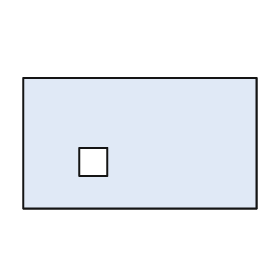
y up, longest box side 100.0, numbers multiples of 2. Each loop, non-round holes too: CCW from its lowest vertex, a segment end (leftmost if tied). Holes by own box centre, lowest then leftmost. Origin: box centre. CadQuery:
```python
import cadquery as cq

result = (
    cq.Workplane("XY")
    .moveTo(-50.0, -28.0)
    .lineTo(50.0, -28.0)
    .lineTo(50.0, 28.0)
    .lineTo(-50.0, 28.0)
    .close()
    .moveTo(-26.0, -14.0)
    .lineTo(-14.0, -14.0)
    .lineTo(-14.0, -2.0)
    .lineTo(-26.0, -2.0)
    .close()
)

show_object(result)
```